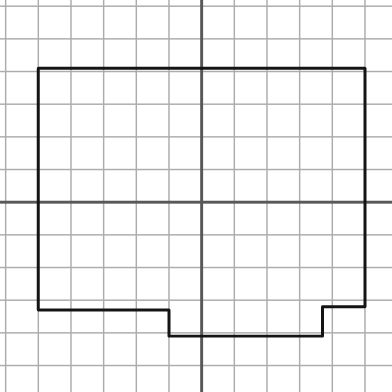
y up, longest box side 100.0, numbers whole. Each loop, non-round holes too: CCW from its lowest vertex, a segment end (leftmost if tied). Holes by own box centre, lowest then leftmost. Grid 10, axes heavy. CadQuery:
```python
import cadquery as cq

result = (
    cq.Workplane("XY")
    .moveTo(-10.0, -41.0)
    .lineTo(37.0, -41.0)
    .lineTo(37.0, -32.0)
    .lineTo(50.0, -32.0)
    .lineTo(50.0, 41.0)
    .lineTo(-50.0, 41.0)
    .lineTo(-50.0, -33.0)
    .lineTo(-10.0, -33.0)
    .close()
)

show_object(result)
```